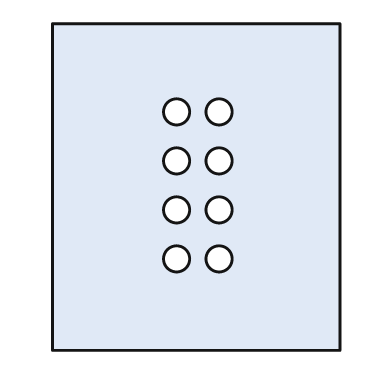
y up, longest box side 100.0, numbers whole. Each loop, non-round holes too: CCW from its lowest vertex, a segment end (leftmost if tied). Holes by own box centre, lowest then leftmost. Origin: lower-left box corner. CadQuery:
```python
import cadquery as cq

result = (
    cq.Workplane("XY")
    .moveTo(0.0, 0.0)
    .lineTo(88.0, 0.0)
    .lineTo(88.0, 100.0)
    .lineTo(0.0, 100.0)
    .close()
    .moveTo(38.0, 28.0)
    .circle(4.0)
    .moveTo(51.0, 28.0)
    .circle(4.0)
    .moveTo(38.0, 43.0)
    .circle(4.0)
    .moveTo(51.0, 43.0)
    .circle(4.0)
    .moveTo(38.0, 58.0)
    .circle(4.0)
    .moveTo(51.0, 58.0)
    .circle(4.0)
    .moveTo(38.0, 73.0)
    .circle(4.0)
    .moveTo(51.0, 73.0)
    .circle(4.0)
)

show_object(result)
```